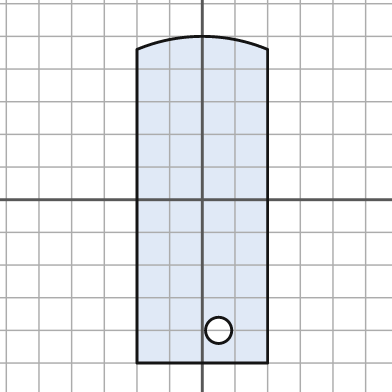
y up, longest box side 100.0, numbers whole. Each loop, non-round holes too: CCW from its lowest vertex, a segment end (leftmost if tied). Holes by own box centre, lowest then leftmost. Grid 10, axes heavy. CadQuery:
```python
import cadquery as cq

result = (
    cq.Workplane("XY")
    .moveTo(-20.0, -50.0)
    .lineTo(20.0, -50.0)
    .lineTo(20.0, 46.0)
    .threePointArc((0.0, 50.0), (-20.0, 46.0))
    .close()
    .moveTo(5.0, -40.0)
    .circle(4.0)
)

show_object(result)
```